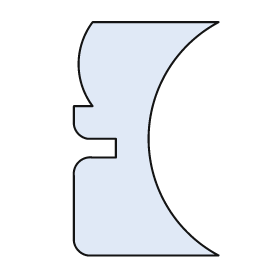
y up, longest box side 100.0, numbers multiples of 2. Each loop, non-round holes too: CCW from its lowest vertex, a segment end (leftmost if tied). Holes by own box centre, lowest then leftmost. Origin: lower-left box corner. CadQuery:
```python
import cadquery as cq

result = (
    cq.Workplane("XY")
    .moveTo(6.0, 0.0)
    .lineTo(62.0, 0.0)
    .threePointArc((32.0, 50.0), (62.0, 100.0))
    .lineTo(8.0, 100.0)
    .threePointArc((2.0, 82.0), (8.0, 64.0))
    .lineTo(0.0, 64.0)
    .lineTo(0.0, 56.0)
    .threePointArc((2.0, 52.0), (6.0, 50.0))
    .lineTo(18.0, 50.0)
    .lineTo(18.0, 42.0)
    .lineTo(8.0, 42.0)
    .threePointArc((2.0, 40.0), (0.0, 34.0))
    .lineTo(0.0, 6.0)
    .threePointArc((2.0, 2.0), (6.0, 0.0))
    .close()
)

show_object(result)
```